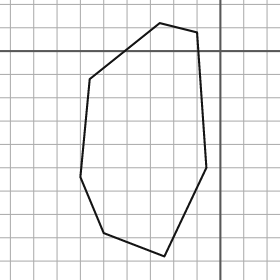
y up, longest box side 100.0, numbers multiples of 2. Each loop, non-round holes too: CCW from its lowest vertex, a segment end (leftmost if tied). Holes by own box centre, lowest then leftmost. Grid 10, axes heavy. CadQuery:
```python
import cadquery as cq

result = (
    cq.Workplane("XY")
    .moveTo(-24.0, -88.0)
    .lineTo(-6.0, -50.0)
    .lineTo(-10.0, 8.0)
    .lineTo(-26.0, 12.0)
    .lineTo(-56.0, -12.0)
    .lineTo(-60.0, -54.0)
    .lineTo(-50.0, -78.0)
    .close()
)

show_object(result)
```